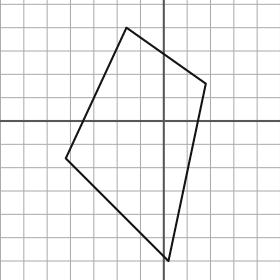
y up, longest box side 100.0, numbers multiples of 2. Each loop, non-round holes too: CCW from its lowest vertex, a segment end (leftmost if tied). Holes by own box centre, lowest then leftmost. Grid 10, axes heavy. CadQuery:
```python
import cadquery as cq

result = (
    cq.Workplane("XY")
    .moveTo(2.0, -60.0)
    .lineTo(18.0, 16.0)
    .lineTo(-16.0, 40.0)
    .lineTo(-42.0, -16.0)
    .close()
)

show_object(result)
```